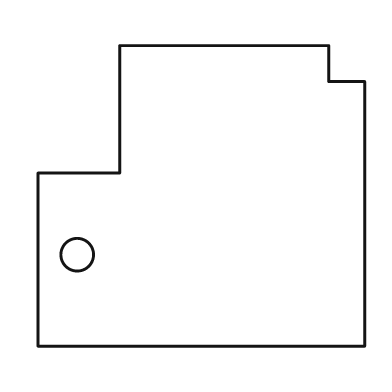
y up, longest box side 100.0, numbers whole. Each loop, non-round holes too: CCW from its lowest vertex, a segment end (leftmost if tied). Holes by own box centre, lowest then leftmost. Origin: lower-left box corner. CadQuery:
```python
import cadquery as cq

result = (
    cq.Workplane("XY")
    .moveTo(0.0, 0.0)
    .lineTo(100.0, 0.0)
    .lineTo(100.0, 81.0)
    .lineTo(89.0, 81.0)
    .lineTo(89.0, 92.0)
    .lineTo(25.0, 92.0)
    .lineTo(25.0, 53.0)
    .lineTo(0.0, 53.0)
    .close()
    .moveTo(12.0, 28.0)
    .circle(5.0)
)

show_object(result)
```